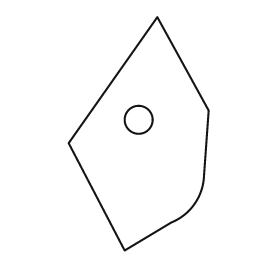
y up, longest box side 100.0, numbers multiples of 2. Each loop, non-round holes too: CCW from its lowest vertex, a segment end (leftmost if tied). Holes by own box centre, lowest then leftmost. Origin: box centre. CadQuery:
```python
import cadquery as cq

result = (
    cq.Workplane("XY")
    .moveTo(-6.0, -50.0)
    .lineTo(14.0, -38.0)
    .threePointArc((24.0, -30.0), (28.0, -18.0))
    .lineTo(30.0, 10.0)
    .lineTo(8.0, 50.0)
    .lineTo(-30.0, -4.0)
    .close()
    .moveTo(0.0, 6.0)
    .circle(6.0)
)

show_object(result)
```